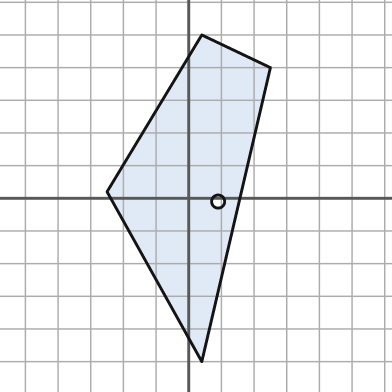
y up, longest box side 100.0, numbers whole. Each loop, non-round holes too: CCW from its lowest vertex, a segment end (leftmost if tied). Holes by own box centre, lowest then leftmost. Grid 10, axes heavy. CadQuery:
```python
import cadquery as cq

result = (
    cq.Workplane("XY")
    .moveTo(4.0, -50.0)
    .lineTo(25.0, 40.0)
    .lineTo(4.0, 50.0)
    .lineTo(-25.0, 2.0)
    .close()
    .moveTo(9.0, -1.0)
    .circle(2.0)
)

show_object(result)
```